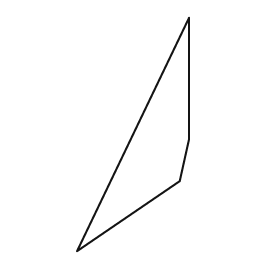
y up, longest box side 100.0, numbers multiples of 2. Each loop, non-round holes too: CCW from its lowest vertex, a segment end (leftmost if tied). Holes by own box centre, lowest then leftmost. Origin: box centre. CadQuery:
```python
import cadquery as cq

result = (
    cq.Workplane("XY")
    .moveTo(-24.0, -50.0)
    .lineTo(20.0, -20.0)
    .lineTo(24.0, -2.0)
    .lineTo(24.0, 50.0)
    .close()
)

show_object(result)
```